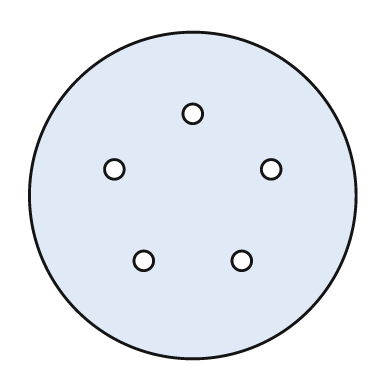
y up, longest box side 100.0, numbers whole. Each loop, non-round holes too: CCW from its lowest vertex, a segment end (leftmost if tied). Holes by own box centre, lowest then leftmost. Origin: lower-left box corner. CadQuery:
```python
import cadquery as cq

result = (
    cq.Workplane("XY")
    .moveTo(50.0, 50.0)
    .circle(50.0)
    .moveTo(35.0, 30.0)
    .circle(3.0)
    .moveTo(65.0, 30.0)
    .circle(3.0)
    .moveTo(26.0, 58.0)
    .circle(3.0)
    .moveTo(74.0, 58.0)
    .circle(3.0)
    .moveTo(50.0, 75.0)
    .circle(3.0)
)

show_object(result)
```